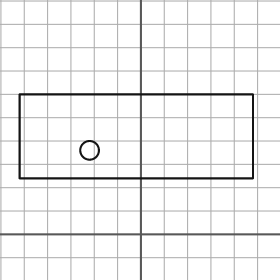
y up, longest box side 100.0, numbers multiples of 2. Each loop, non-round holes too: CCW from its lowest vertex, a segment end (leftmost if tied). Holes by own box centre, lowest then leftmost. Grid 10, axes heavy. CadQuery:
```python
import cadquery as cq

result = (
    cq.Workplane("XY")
    .moveTo(-52.0, 24.0)
    .lineTo(48.0, 24.0)
    .lineTo(48.0, 60.0)
    .lineTo(-52.0, 60.0)
    .close()
    .moveTo(-22.0, 36.0)
    .circle(4.0)
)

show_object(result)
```